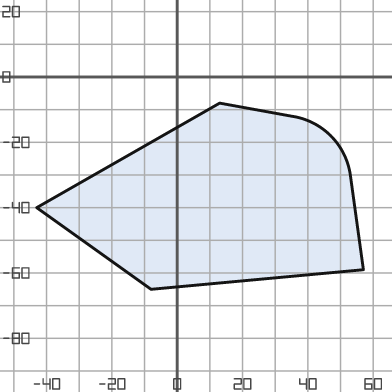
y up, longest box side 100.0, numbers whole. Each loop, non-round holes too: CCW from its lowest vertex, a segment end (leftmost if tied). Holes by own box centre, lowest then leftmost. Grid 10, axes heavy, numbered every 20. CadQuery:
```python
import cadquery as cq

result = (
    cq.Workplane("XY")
    .moveTo(-8.0, -65.0)
    .lineTo(57.0, -59.0)
    .lineTo(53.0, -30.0)
    .threePointArc((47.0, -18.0), (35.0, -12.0))
    .lineTo(13.0, -8.0)
    .lineTo(-43.0, -40.0)
    .close()
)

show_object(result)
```